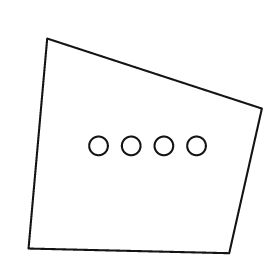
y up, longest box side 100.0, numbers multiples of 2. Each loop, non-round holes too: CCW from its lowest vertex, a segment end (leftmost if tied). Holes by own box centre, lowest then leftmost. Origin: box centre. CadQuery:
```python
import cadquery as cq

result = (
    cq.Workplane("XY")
    .moveTo(36.0, -46.0)
    .lineTo(50.0, 16.0)
    .lineTo(-42.0, 46.0)
    .lineTo(-50.0, -44.0)
    .close()
    .moveTo(-20.0, 0.0)
    .circle(4.0)
    .moveTo(-6.0, 0.0)
    .circle(4.0)
    .moveTo(8.0, 0.0)
    .circle(4.0)
    .moveTo(22.0, 0.0)
    .circle(4.0)
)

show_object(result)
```